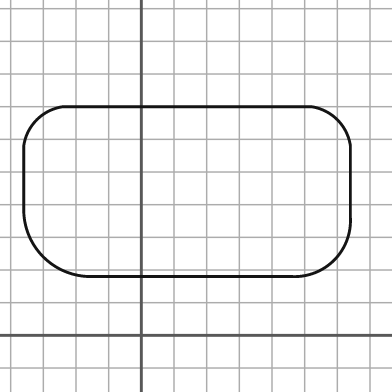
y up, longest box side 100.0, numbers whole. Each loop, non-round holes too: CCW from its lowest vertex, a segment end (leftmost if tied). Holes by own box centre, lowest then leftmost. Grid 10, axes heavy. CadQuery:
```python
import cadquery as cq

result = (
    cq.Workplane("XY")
    .moveTo(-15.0, 18.0)
    .lineTo(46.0, 18.0)
    .threePointArc((59.0, 23.0), (64.0, 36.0))
    .lineTo(64.0, 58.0)
    .threePointArc((60.0, 66.0), (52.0, 70.0))
    .lineTo(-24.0, 70.0)
    .threePointArc((-32.0, 66.0), (-36.0, 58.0))
    .lineTo(-36.0, 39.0)
    .threePointArc((-30.0, 24.0), (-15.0, 18.0))
    .close()
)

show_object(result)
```